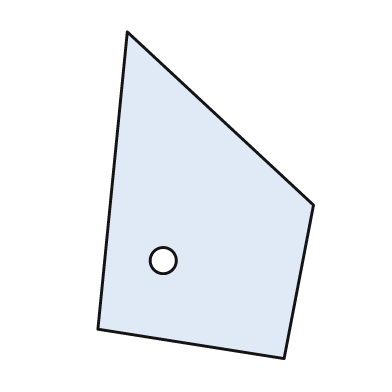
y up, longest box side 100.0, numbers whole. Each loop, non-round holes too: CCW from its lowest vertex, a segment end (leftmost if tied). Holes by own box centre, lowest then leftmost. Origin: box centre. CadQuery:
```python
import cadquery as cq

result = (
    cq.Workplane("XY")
    .moveTo(24.0, -50.0)
    .lineTo(33.0, -3.0)
    .lineTo(-24.0, 50.0)
    .lineTo(-33.0, -41.0)
    .close()
    .moveTo(-13.0, -20.0)
    .circle(4.0)
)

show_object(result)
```